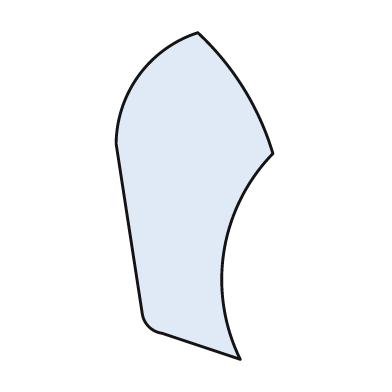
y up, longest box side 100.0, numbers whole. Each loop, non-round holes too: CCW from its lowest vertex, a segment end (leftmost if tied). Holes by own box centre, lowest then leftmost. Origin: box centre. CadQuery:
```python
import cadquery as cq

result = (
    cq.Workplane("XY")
    .moveTo(14.0, -50.0)
    .threePointArc((9.0, -17.0), (24.0, 13.0))
    .threePointArc((15.0, 33.0), (1.0, 50.0))
    .threePointArc((-17.0, 37.0), (-24.0, 16.0))
    .lineTo(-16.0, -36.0)
    .threePointArc((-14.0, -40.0), (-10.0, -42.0))
    .close()
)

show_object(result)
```